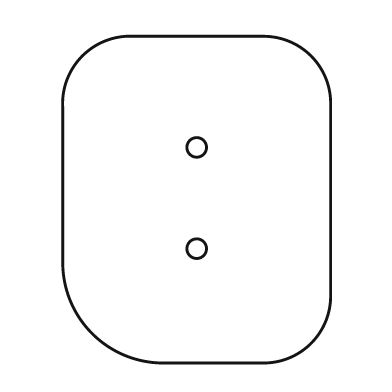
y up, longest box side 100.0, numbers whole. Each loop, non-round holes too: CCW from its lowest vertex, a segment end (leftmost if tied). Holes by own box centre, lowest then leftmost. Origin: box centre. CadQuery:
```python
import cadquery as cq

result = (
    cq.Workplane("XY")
    .moveTo(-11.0, -50.0)
    .lineTo(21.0, -50.0)
    .threePointArc((35.0, -44.0), (41.0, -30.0))
    .lineTo(41.0, 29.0)
    .threePointArc((35.0, 44.0), (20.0, 50.0))
    .lineTo(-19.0, 50.0)
    .threePointArc((-35.0, 44.0), (-41.0, 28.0))
    .lineTo(-41.0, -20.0)
    .threePointArc((-32.0, -41.0), (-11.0, -50.0))
    .close()
    .moveTo(0.0, -15.0)
    .circle(3.0)
    .moveTo(0.0, 16.0)
    .circle(3.0)
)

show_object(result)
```